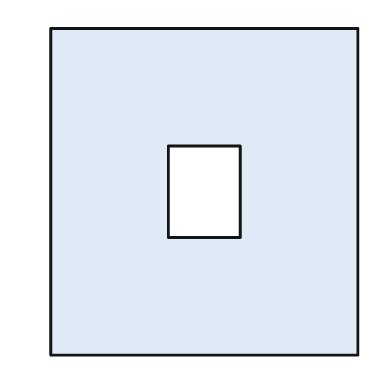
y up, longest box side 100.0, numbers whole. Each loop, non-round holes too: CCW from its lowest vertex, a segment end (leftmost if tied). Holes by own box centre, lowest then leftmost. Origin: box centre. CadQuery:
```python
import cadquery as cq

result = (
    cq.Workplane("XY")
    .moveTo(-47.0, -50.0)
    .lineTo(47.0, -50.0)
    .lineTo(47.0, 50.0)
    .lineTo(-47.0, 50.0)
    .close()
    .moveTo(-11.0, -14.0)
    .lineTo(11.0, -14.0)
    .lineTo(11.0, 14.0)
    .lineTo(-11.0, 14.0)
    .close()
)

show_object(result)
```